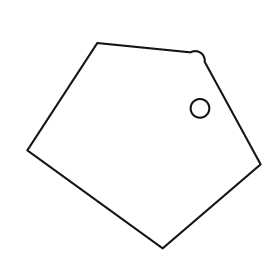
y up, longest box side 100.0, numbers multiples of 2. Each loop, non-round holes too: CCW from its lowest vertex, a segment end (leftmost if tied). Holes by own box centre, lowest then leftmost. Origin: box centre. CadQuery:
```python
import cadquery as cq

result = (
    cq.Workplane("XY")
    .moveTo(8.0, -44.0)
    .lineTo(50.0, -8.0)
    .lineTo(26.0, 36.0)
    .threePointArc((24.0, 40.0), (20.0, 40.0))
    .lineTo(-20.0, 44.0)
    .lineTo(-50.0, -2.0)
    .close()
    .moveTo(24.0, 16.0)
    .circle(4.0)
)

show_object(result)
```